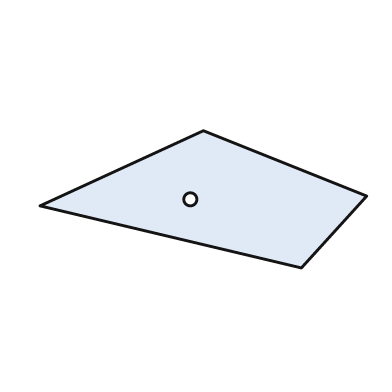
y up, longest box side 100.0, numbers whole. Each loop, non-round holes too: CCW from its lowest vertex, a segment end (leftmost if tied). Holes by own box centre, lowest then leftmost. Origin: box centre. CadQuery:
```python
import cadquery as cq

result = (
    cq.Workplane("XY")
    .moveTo(30.0, -21.0)
    .lineTo(50.0, 1.0)
    .lineTo(0.0, 21.0)
    .lineTo(-50.0, -2.0)
    .close()
    .moveTo(-4.0, 0.0)
    .circle(2.0)
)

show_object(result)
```